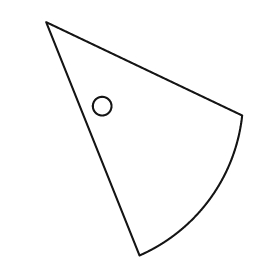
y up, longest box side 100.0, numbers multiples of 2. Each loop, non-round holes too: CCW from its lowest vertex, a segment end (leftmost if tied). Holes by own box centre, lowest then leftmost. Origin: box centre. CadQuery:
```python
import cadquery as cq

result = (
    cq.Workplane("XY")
    .moveTo(-2.0, -50.0)
    .threePointArc((28.0, -26.0), (42.0, 10.0))
    .lineTo(-42.0, 50.0)
    .close()
    .moveTo(-18.0, 14.0)
    .circle(4.0)
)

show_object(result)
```